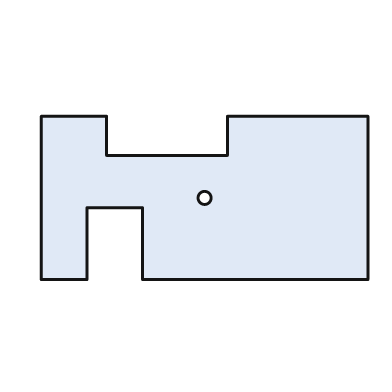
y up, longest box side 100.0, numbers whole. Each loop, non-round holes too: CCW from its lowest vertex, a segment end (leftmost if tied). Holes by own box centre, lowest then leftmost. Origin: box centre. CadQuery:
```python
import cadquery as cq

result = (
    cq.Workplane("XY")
    .moveTo(-50.0, -25.0)
    .lineTo(-36.0, -25.0)
    .lineTo(-36.0, -3.0)
    .lineTo(-19.0, -3.0)
    .lineTo(-19.0, -25.0)
    .lineTo(50.0, -25.0)
    .lineTo(50.0, 25.0)
    .lineTo(7.0, 25.0)
    .lineTo(7.0, 13.0)
    .lineTo(-30.0, 13.0)
    .lineTo(-30.0, 25.0)
    .lineTo(-50.0, 25.0)
    .close()
    .moveTo(0.0, 0.0)
    .circle(2.0)
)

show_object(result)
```